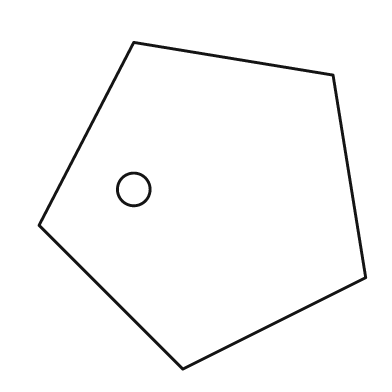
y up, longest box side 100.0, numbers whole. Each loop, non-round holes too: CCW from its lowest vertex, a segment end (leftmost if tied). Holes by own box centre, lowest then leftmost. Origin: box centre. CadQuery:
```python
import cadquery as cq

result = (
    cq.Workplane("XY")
    .moveTo(-6.0, -50.0)
    .lineTo(50.0, -22.0)
    .lineTo(40.0, 40.0)
    .lineTo(-21.0, 50.0)
    .lineTo(-50.0, -6.0)
    .close()
    .moveTo(-21.0, 5.0)
    .circle(5.0)
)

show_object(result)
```